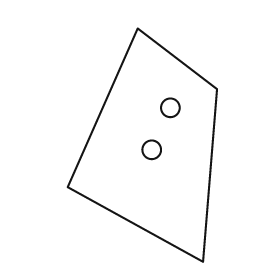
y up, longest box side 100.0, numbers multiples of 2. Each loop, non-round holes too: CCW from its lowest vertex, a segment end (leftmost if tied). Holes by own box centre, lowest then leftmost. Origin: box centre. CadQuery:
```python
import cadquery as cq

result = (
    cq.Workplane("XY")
    .moveTo(26.0, -50.0)
    .lineTo(32.0, 24.0)
    .lineTo(-2.0, 50.0)
    .lineTo(-32.0, -18.0)
    .close()
    .moveTo(4.0, -2.0)
    .circle(4.0)
    .moveTo(12.0, 16.0)
    .circle(4.0)
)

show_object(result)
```